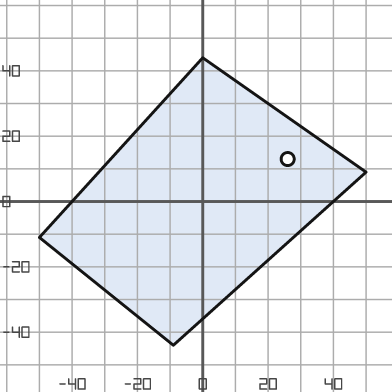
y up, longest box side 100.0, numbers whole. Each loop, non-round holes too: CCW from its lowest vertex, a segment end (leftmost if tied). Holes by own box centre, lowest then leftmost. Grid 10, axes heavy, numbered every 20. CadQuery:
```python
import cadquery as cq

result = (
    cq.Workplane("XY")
    .moveTo(-9.0, -44.0)
    .lineTo(50.0, 9.0)
    .lineTo(0.0, 44.0)
    .lineTo(-50.0, -11.0)
    .close()
    .moveTo(26.0, 13.0)
    .circle(2.0)
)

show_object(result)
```